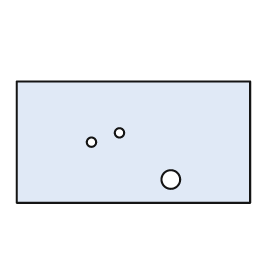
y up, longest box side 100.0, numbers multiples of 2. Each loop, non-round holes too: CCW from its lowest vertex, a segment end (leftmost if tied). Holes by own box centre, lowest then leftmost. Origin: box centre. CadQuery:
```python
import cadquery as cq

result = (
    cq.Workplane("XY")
    .moveTo(-50.0, -26.0)
    .lineTo(50.0, -26.0)
    .lineTo(50.0, 26.0)
    .lineTo(-50.0, 26.0)
    .close()
    .moveTo(16.0, -16.0)
    .circle(4.0)
    .moveTo(-18.0, 0.0)
    .circle(2.0)
    .moveTo(-6.0, 4.0)
    .circle(2.0)
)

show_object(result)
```